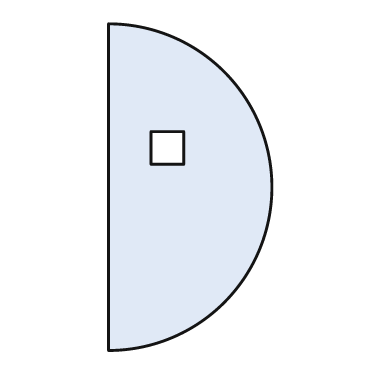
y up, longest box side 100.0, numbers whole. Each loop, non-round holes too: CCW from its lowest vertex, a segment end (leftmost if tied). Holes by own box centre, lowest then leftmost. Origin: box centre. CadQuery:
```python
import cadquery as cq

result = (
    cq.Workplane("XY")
    .moveTo(-25.0, -50.0)
    .threePointArc((25.0, 0.0), (-25.0, 50.0))
    .close()
    .moveTo(-12.0, 7.0)
    .lineTo(-2.0, 7.0)
    .lineTo(-2.0, 17.0)
    .lineTo(-12.0, 17.0)
    .close()
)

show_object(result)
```